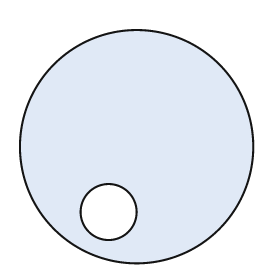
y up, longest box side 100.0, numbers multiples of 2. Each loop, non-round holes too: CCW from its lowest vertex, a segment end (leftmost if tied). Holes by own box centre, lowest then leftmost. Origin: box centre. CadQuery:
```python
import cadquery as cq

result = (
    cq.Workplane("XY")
    .moveTo(0.0, 0.0)
    .circle(50.0)
    .moveTo(-12.0, -28.0)
    .circle(12.0)
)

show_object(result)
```